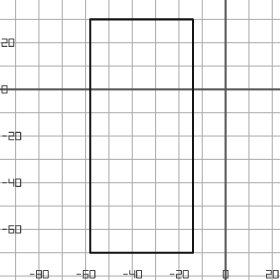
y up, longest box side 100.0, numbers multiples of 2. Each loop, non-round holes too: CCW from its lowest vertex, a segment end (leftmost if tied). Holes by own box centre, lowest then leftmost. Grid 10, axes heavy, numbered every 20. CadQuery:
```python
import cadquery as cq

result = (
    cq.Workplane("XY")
    .moveTo(-58.0, -70.0)
    .lineTo(-14.0, -70.0)
    .lineTo(-14.0, 30.0)
    .lineTo(-58.0, 30.0)
    .close()
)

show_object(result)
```